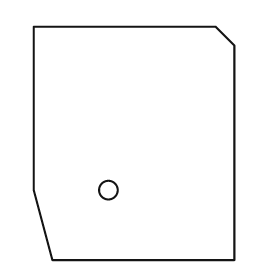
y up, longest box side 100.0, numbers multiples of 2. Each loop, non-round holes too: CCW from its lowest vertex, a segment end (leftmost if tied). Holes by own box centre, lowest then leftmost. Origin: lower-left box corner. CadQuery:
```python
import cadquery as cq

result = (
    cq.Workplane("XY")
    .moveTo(8.0, 0.0)
    .lineTo(86.0, 0.0)
    .lineTo(86.0, 92.0)
    .lineTo(78.0, 100.0)
    .lineTo(0.0, 100.0)
    .lineTo(0.0, 30.0)
    .close()
    .moveTo(32.0, 30.0)
    .circle(4.0)
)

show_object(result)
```